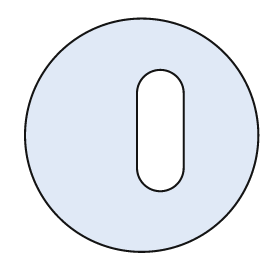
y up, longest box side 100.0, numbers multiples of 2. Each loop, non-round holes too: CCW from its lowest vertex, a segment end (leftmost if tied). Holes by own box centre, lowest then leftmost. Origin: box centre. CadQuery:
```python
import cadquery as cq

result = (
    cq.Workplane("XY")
    .moveTo(0.0, 0.0)
    .circle(50.0)
    .moveTo(-2.0, -14.0)
    .threePointArc((8.0, -24.0), (18.0, -14.0))
    .lineTo(18.0, 18.0)
    .threePointArc((8.0, 28.0), (-2.0, 18.0))
    .close()
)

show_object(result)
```